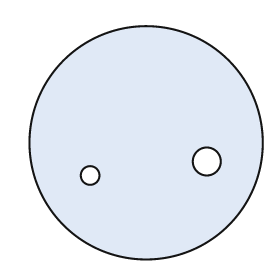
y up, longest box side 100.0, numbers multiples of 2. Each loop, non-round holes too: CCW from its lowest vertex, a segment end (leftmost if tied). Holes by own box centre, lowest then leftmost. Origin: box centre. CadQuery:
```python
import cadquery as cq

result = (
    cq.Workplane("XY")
    .moveTo(0.0, 0.0)
    .circle(50.0)
    .moveTo(-24.0, -14.0)
    .circle(4.0)
    .moveTo(26.0, -8.0)
    .circle(6.0)
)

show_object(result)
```